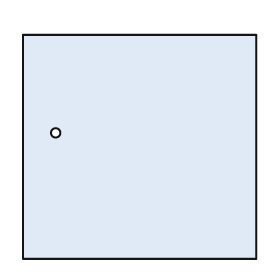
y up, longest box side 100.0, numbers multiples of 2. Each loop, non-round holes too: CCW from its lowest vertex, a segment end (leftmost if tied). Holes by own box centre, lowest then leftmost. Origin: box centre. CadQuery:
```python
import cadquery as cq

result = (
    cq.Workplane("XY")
    .moveTo(-50.0, -48.0)
    .lineTo(50.0, -48.0)
    .lineTo(50.0, 48.0)
    .lineTo(-50.0, 48.0)
    .close()
    .moveTo(-36.0, 6.0)
    .circle(2.0)
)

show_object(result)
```